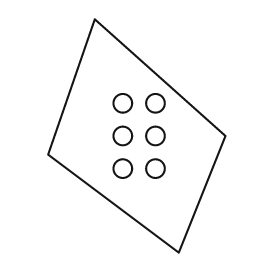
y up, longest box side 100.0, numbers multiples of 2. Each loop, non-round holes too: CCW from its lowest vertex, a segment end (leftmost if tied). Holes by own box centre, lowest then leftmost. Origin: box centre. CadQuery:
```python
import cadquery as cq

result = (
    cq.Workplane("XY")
    .moveTo(18.0, -50.0)
    .lineTo(38.0, 0.0)
    .lineTo(-18.0, 50.0)
    .lineTo(-38.0, -8.0)
    .close()
    .moveTo(-6.0, -14.0)
    .circle(4.0)
    .moveTo(8.0, -14.0)
    .circle(4.0)
    .moveTo(-6.0, 0.0)
    .circle(4.0)
    .moveTo(8.0, 0.0)
    .circle(4.0)
    .moveTo(-6.0, 14.0)
    .circle(4.0)
    .moveTo(8.0, 14.0)
    .circle(4.0)
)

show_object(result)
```